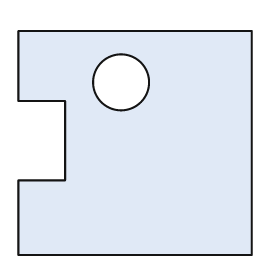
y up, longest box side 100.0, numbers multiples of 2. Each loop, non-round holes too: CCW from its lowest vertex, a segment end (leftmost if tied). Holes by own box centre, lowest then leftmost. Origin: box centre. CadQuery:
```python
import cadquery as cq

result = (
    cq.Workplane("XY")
    .moveTo(-50.0, -48.0)
    .lineTo(50.0, -48.0)
    .lineTo(50.0, 48.0)
    .lineTo(-50.0, 48.0)
    .lineTo(-50.0, 18.0)
    .lineTo(-30.0, 18.0)
    .lineTo(-30.0, -16.0)
    .lineTo(-50.0, -16.0)
    .close()
    .moveTo(-6.0, 26.0)
    .circle(12.0)
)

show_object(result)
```